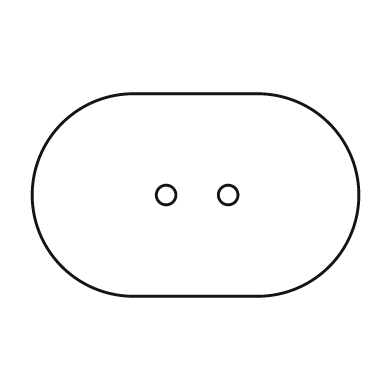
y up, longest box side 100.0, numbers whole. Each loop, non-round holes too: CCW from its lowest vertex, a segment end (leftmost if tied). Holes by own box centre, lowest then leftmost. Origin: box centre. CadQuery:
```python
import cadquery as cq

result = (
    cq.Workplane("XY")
    .moveTo(-19.0, -31.0)
    .lineTo(19.0, -31.0)
    .threePointArc((50.0, 0.0), (19.0, 31.0))
    .lineTo(-19.0, 31.0)
    .threePointArc((-50.0, 0.0), (-19.0, -31.0))
    .close()
    .moveTo(-9.0, 0.0)
    .circle(3.0)
    .moveTo(10.0, 0.0)
    .circle(3.0)
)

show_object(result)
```